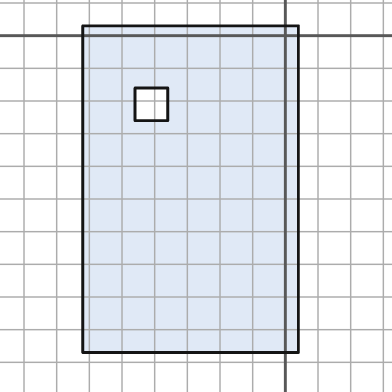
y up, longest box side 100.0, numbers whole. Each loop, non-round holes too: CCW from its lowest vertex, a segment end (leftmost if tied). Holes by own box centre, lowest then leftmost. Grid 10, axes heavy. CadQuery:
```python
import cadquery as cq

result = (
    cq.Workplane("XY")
    .moveTo(-62.0, -97.0)
    .lineTo(4.0, -97.0)
    .lineTo(4.0, 3.0)
    .lineTo(-62.0, 3.0)
    .close()
    .moveTo(-46.0, -26.0)
    .lineTo(-36.0, -26.0)
    .lineTo(-36.0, -16.0)
    .lineTo(-46.0, -16.0)
    .close()
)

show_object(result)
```